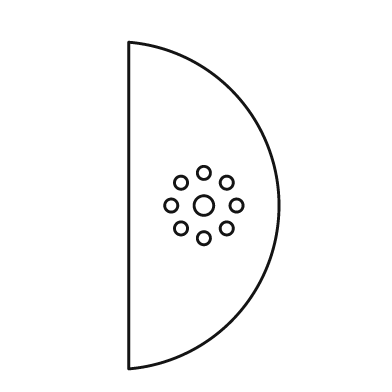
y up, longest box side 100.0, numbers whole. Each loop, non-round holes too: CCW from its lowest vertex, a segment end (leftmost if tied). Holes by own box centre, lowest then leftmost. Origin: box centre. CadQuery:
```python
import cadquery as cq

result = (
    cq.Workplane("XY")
    .moveTo(-23.0, -50.0)
    .threePointArc((23.0, 0.0), (-23.0, 50.0))
    .close()
    .moveTo(0.0, -10.0)
    .circle(2.0)
    .moveTo(-7.0, -7.0)
    .circle(2.0)
    .moveTo(7.0, -7.0)
    .circle(2.0)
    .moveTo(-10.0, 0.0)
    .circle(2.0)
    .moveTo(0.0, 0.0)
    .circle(3.0)
    .moveTo(10.0, 0.0)
    .circle(2.0)
    .moveTo(-7.0, 7.0)
    .circle(2.0)
    .moveTo(7.0, 7.0)
    .circle(2.0)
    .moveTo(0.0, 10.0)
    .circle(2.0)
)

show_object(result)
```